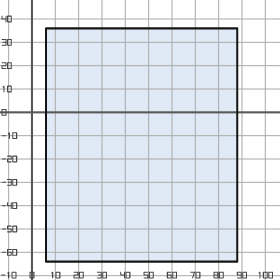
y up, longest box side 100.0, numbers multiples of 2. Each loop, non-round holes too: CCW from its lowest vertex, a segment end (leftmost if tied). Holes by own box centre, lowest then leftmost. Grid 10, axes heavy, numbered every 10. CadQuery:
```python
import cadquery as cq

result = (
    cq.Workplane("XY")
    .moveTo(6.0, -64.0)
    .lineTo(88.0, -64.0)
    .lineTo(88.0, 36.0)
    .lineTo(6.0, 36.0)
    .close()
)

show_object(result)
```